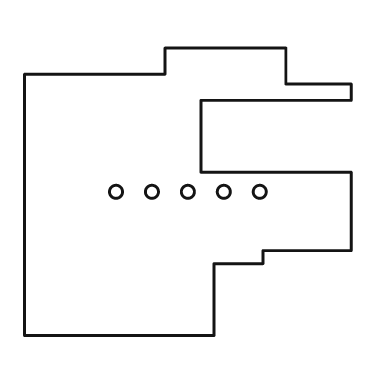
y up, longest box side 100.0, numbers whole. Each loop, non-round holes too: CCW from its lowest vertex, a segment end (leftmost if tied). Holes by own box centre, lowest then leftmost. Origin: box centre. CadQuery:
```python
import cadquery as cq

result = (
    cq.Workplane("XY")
    .moveTo(-50.0, -44.0)
    .lineTo(8.0, -44.0)
    .lineTo(8.0, -22.0)
    .lineTo(23.0, -22.0)
    .lineTo(23.0, -18.0)
    .lineTo(50.0, -18.0)
    .lineTo(50.0, 6.0)
    .lineTo(4.0, 6.0)
    .lineTo(4.0, 28.0)
    .lineTo(50.0, 28.0)
    .lineTo(50.0, 33.0)
    .lineTo(30.0, 33.0)
    .lineTo(30.0, 44.0)
    .lineTo(-7.0, 44.0)
    .lineTo(-7.0, 36.0)
    .lineTo(-50.0, 36.0)
    .close()
    .moveTo(-22.0, 0.0)
    .circle(2.0)
    .moveTo(-11.0, 0.0)
    .circle(2.0)
    .moveTo(0.0, 0.0)
    .circle(2.0)
    .moveTo(11.0, 0.0)
    .circle(2.0)
    .moveTo(22.0, 0.0)
    .circle(2.0)
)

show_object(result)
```